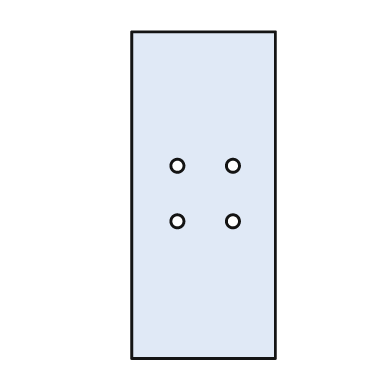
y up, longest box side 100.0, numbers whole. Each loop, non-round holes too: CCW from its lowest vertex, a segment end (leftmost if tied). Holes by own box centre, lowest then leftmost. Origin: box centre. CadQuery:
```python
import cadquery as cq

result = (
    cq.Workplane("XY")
    .moveTo(-22.0, -50.0)
    .lineTo(22.0, -50.0)
    .lineTo(22.0, 50.0)
    .lineTo(-22.0, 50.0)
    .close()
    .moveTo(-8.0, -8.0)
    .circle(2.0)
    .moveTo(9.0, -8.0)
    .circle(2.0)
    .moveTo(-8.0, 9.0)
    .circle(2.0)
    .moveTo(9.0, 9.0)
    .circle(2.0)
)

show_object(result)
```